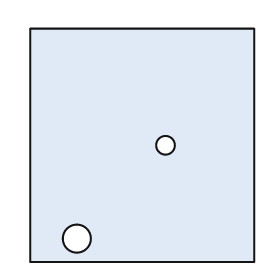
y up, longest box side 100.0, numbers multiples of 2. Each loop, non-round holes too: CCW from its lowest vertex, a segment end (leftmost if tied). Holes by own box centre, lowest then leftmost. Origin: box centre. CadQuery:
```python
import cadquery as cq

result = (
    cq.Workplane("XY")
    .moveTo(-48.0, -50.0)
    .lineTo(48.0, -50.0)
    .lineTo(48.0, 50.0)
    .lineTo(-48.0, 50.0)
    .close()
    .moveTo(-28.0, -40.0)
    .circle(6.0)
    .moveTo(10.0, 0.0)
    .circle(4.0)
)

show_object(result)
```